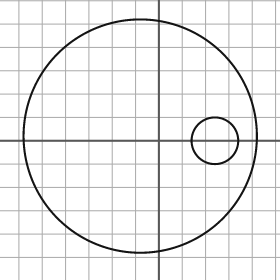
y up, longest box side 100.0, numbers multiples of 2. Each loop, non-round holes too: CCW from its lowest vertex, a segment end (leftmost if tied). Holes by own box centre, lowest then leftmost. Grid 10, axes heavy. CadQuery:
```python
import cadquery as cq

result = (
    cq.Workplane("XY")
    .moveTo(-8.0, 2.0)
    .circle(50.0)
    .moveTo(24.0, 0.0)
    .circle(10.0)
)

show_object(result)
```